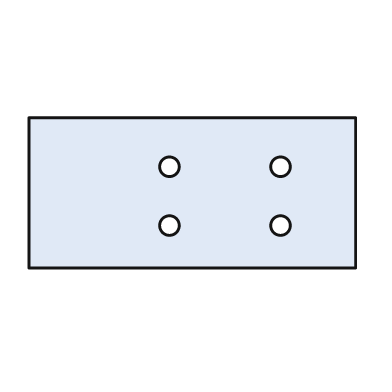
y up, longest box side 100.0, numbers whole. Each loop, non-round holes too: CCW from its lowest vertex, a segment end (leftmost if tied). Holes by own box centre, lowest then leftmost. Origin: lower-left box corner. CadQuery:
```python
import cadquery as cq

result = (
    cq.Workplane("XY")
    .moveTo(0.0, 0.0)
    .lineTo(100.0, 0.0)
    .lineTo(100.0, 46.0)
    .lineTo(0.0, 46.0)
    .close()
    .moveTo(43.0, 13.0)
    .circle(3.0)
    .moveTo(77.0, 13.0)
    .circle(3.0)
    .moveTo(43.0, 31.0)
    .circle(3.0)
    .moveTo(77.0, 31.0)
    .circle(3.0)
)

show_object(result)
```